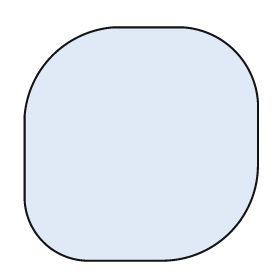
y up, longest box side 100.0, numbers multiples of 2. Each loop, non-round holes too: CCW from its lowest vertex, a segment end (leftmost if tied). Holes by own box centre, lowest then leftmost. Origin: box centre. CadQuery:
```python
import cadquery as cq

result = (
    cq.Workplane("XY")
    .moveTo(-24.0, -50.0)
    .lineTo(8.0, -50.0)
    .threePointArc((38.0, -38.0), (50.0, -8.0))
    .lineTo(50.0, 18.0)
    .threePointArc((40.0, 40.0), (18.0, 50.0))
    .lineTo(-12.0, 50.0)
    .threePointArc((-38.0, 38.0), (-50.0, 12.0))
    .lineTo(-50.0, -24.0)
    .threePointArc((-42.0, -42.0), (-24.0, -50.0))
    .close()
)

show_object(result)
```